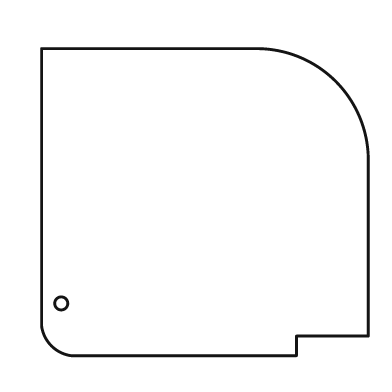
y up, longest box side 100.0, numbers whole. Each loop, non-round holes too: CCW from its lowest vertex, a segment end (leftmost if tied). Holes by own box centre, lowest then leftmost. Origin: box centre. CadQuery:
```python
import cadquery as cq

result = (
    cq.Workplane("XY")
    .moveTo(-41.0, -47.0)
    .lineTo(28.0, -47.0)
    .lineTo(28.0, -41.0)
    .lineTo(50.0, -41.0)
    .lineTo(50.0, 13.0)
    .threePointArc((40.0, 37.0), (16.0, 47.0))
    .lineTo(-50.0, 47.0)
    .lineTo(-50.0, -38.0)
    .threePointArc((-47.0, -44.0), (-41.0, -47.0))
    .close()
    .moveTo(-44.0, -31.0)
    .circle(2.0)
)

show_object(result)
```